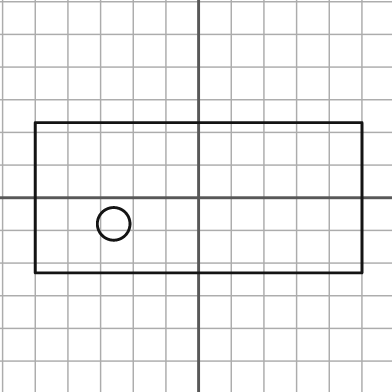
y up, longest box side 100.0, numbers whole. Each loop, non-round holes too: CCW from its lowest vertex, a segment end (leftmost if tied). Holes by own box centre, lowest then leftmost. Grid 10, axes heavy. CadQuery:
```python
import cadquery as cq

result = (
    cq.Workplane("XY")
    .moveTo(-50.0, -23.0)
    .lineTo(50.0, -23.0)
    .lineTo(50.0, 23.0)
    .lineTo(-50.0, 23.0)
    .close()
    .moveTo(-26.0, -8.0)
    .circle(5.0)
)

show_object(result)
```